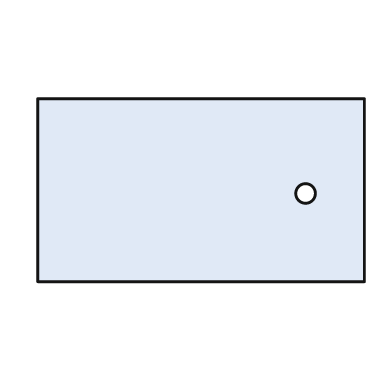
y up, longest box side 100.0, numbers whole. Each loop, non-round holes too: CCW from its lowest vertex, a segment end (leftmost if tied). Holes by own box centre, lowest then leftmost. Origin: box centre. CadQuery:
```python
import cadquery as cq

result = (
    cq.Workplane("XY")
    .moveTo(-50.0, -28.0)
    .lineTo(50.0, -28.0)
    .lineTo(50.0, 28.0)
    .lineTo(-50.0, 28.0)
    .close()
    .moveTo(32.0, -1.0)
    .circle(3.0)
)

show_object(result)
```